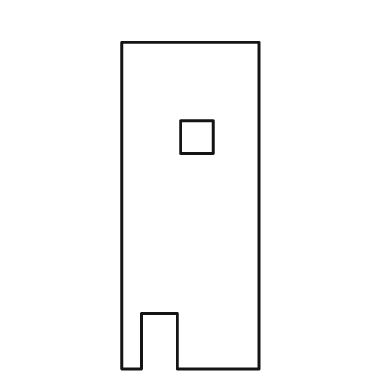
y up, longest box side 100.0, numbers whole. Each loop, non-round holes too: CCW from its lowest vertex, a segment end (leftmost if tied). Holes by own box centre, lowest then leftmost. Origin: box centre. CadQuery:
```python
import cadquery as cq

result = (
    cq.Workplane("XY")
    .moveTo(-21.0, -50.0)
    .lineTo(-15.0, -50.0)
    .lineTo(-15.0, -33.0)
    .lineTo(-4.0, -33.0)
    .lineTo(-4.0, -50.0)
    .lineTo(21.0, -50.0)
    .lineTo(21.0, 50.0)
    .lineTo(-21.0, 50.0)
    .close()
    .moveTo(-3.0, 16.0)
    .lineTo(7.0, 16.0)
    .lineTo(7.0, 26.0)
    .lineTo(-3.0, 26.0)
    .close()
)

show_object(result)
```